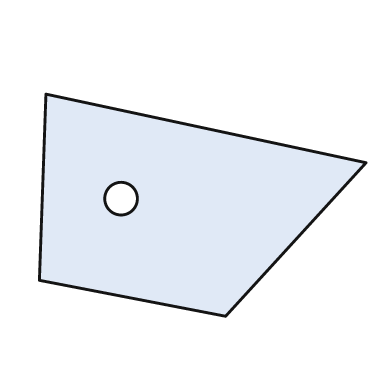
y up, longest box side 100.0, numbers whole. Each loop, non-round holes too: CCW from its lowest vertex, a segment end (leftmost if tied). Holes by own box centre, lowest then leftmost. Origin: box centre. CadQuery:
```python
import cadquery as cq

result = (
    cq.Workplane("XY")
    .moveTo(7.0, -34.0)
    .lineTo(50.0, 13.0)
    .lineTo(-48.0, 34.0)
    .lineTo(-50.0, -23.0)
    .close()
    .moveTo(-25.0, 2.0)
    .circle(5.0)
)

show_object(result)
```